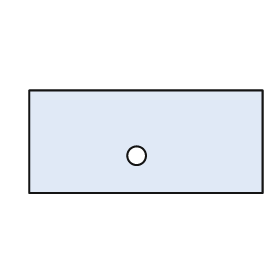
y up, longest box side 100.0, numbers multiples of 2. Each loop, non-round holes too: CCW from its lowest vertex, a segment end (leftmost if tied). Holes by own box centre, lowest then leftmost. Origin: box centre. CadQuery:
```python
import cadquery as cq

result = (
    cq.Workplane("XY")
    .moveTo(-50.0, -22.0)
    .lineTo(50.0, -22.0)
    .lineTo(50.0, 22.0)
    .lineTo(-50.0, 22.0)
    .close()
    .moveTo(-4.0, -6.0)
    .circle(4.0)
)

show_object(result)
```